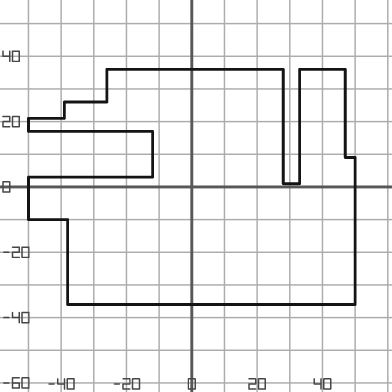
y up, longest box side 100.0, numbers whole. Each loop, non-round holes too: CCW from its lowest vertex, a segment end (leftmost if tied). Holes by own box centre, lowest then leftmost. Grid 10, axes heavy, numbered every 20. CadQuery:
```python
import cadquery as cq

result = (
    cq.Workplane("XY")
    .moveTo(-38.0, -36.0)
    .lineTo(50.0, -36.0)
    .lineTo(50.0, 9.0)
    .lineTo(47.0, 9.0)
    .lineTo(47.0, 36.0)
    .lineTo(33.0, 36.0)
    .lineTo(33.0, 1.0)
    .lineTo(28.0, 1.0)
    .lineTo(28.0, 36.0)
    .lineTo(-26.0, 36.0)
    .lineTo(-26.0, 26.0)
    .lineTo(-39.0, 26.0)
    .lineTo(-39.0, 21.0)
    .lineTo(-50.0, 21.0)
    .lineTo(-50.0, 17.0)
    .lineTo(-12.0, 17.0)
    .lineTo(-12.0, 3.0)
    .lineTo(-50.0, 3.0)
    .lineTo(-50.0, -10.0)
    .lineTo(-38.0, -10.0)
    .close()
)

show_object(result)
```